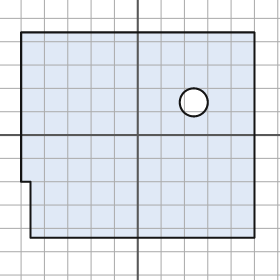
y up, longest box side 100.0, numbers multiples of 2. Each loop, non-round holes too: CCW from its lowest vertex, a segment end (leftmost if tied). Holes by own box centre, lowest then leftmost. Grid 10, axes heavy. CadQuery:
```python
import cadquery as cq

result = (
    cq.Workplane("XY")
    .moveTo(-46.0, -44.0)
    .lineTo(50.0, -44.0)
    .lineTo(50.0, 44.0)
    .lineTo(-50.0, 44.0)
    .lineTo(-50.0, -20.0)
    .lineTo(-46.0, -20.0)
    .close()
    .moveTo(24.0, 14.0)
    .circle(6.0)
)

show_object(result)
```